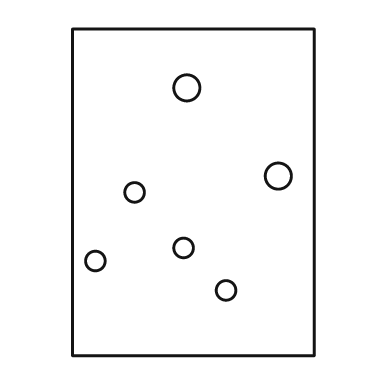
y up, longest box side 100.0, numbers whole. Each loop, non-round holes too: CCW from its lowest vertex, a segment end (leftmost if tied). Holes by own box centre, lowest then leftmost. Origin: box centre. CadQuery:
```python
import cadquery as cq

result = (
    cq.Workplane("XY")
    .moveTo(-37.0, -50.0)
    .lineTo(37.0, -50.0)
    .lineTo(37.0, 50.0)
    .lineTo(-37.0, 50.0)
    .close()
    .moveTo(10.0, -30.0)
    .circle(3.0)
    .moveTo(-30.0, -21.0)
    .circle(3.0)
    .moveTo(-3.0, -17.0)
    .circle(3.0)
    .moveTo(-18.0, 0.0)
    .circle(3.0)
    .moveTo(26.0, 5.0)
    .circle(4.0)
    .moveTo(-2.0, 32.0)
    .circle(4.0)
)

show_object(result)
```